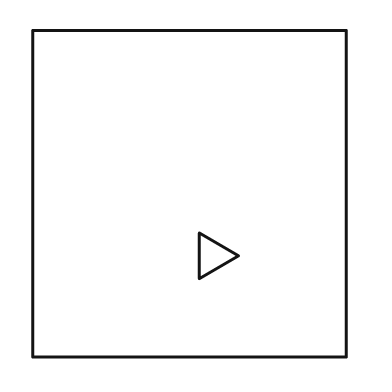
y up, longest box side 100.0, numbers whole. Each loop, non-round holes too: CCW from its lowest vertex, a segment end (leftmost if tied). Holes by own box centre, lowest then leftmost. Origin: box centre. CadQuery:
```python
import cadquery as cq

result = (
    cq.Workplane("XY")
    .moveTo(-48.0, -50.0)
    .lineTo(48.0, -50.0)
    .lineTo(48.0, 50.0)
    .lineTo(-48.0, 50.0)
    .close()
    .moveTo(3.0, -26.0)
    .lineTo(15.0, -19.0)
    .lineTo(3.0, -12.0)
    .close()
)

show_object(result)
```